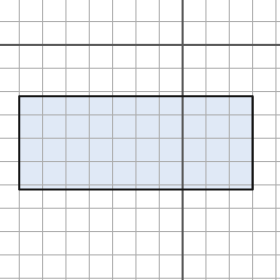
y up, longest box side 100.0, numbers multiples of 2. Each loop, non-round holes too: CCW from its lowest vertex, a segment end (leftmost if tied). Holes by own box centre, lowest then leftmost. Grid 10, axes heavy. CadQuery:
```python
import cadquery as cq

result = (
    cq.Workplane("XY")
    .moveTo(-70.0, -62.0)
    .lineTo(30.0, -62.0)
    .lineTo(30.0, -22.0)
    .lineTo(-70.0, -22.0)
    .close()
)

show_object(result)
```